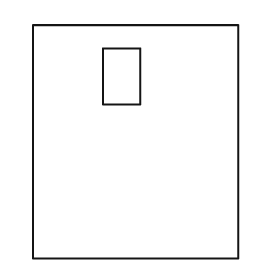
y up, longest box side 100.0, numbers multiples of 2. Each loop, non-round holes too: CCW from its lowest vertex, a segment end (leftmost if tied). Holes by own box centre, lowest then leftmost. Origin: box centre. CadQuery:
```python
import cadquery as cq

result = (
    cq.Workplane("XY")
    .moveTo(-44.0, -50.0)
    .lineTo(44.0, -50.0)
    .lineTo(44.0, 50.0)
    .lineTo(-44.0, 50.0)
    .close()
    .moveTo(-14.0, 16.0)
    .lineTo(2.0, 16.0)
    .lineTo(2.0, 40.0)
    .lineTo(-14.0, 40.0)
    .close()
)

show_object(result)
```